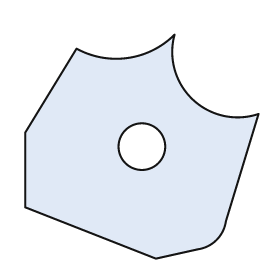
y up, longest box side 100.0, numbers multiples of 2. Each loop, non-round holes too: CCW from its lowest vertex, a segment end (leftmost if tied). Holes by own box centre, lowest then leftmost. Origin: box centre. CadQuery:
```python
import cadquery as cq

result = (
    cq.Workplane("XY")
    .moveTo(6.0, -48.0)
    .lineTo(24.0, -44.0)
    .threePointArc((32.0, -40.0), (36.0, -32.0))
    .lineTo(50.0, 14.0)
    .threePointArc((22.0, 20.0), (14.0, 48.0))
    .threePointArc((-6.0, 38.0), (-28.0, 42.0))
    .lineTo(-50.0, 6.0)
    .lineTo(-50.0, -26.0)
    .close()
    .moveTo(0.0, 0.0)
    .circle(10.0)
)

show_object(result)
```